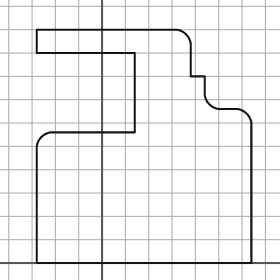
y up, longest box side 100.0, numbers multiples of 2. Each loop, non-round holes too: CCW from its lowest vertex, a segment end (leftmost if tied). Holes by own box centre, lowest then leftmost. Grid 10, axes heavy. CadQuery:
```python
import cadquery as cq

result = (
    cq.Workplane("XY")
    .moveTo(-28.0, 0.0)
    .lineTo(64.0, 0.0)
    .lineTo(64.0, 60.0)
    .threePointArc((62.0, 64.0), (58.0, 66.0))
    .lineTo(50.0, 66.0)
    .threePointArc((46.0, 68.0), (44.0, 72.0))
    .lineTo(44.0, 80.0)
    .lineTo(38.0, 80.0)
    .lineTo(38.0, 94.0)
    .threePointArc((36.0, 98.0), (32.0, 100.0))
    .lineTo(-28.0, 100.0)
    .lineTo(-28.0, 90.0)
    .lineTo(14.0, 90.0)
    .lineTo(14.0, 56.0)
    .lineTo(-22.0, 56.0)
    .threePointArc((-26.0, 54.0), (-28.0, 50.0))
    .close()
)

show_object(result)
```